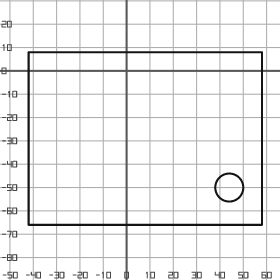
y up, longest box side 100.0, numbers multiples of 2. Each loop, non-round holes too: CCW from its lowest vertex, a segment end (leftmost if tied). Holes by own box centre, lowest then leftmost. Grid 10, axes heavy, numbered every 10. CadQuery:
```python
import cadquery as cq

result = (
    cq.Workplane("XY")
    .moveTo(-42.0, -66.0)
    .lineTo(58.0, -66.0)
    .lineTo(58.0, 8.0)
    .lineTo(-42.0, 8.0)
    .close()
    .moveTo(44.0, -50.0)
    .circle(6.0)
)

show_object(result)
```